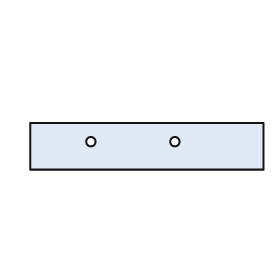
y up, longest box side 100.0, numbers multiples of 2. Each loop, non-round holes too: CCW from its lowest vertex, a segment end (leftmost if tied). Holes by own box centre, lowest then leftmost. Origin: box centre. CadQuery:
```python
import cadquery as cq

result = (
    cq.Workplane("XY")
    .moveTo(-50.0, -10.0)
    .lineTo(50.0, -10.0)
    .lineTo(50.0, 10.0)
    .lineTo(-50.0, 10.0)
    .close()
    .moveTo(-24.0, 2.0)
    .circle(2.0)
    .moveTo(12.0, 2.0)
    .circle(2.0)
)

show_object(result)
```